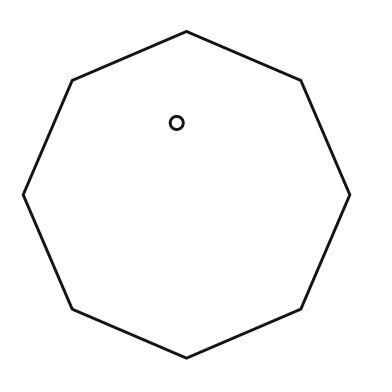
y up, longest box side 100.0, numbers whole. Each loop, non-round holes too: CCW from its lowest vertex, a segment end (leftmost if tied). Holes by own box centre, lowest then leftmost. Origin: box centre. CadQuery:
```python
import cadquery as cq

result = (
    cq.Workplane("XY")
    .moveTo(0.0, -50.0)
    .lineTo(35.0, -35.0)
    .lineTo(50.0, 0.0)
    .lineTo(35.0, 35.0)
    .lineTo(0.0, 50.0)
    .lineTo(-35.0, 35.0)
    .lineTo(-50.0, 0.0)
    .lineTo(-35.0, -35.0)
    .close()
    .moveTo(-3.0, 22.0)
    .circle(2.0)
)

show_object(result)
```